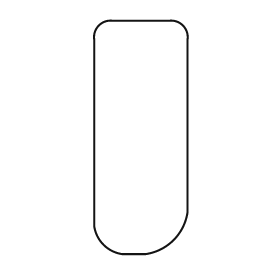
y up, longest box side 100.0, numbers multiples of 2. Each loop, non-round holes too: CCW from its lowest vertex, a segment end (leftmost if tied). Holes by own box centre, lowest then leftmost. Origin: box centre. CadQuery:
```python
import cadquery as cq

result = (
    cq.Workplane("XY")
    .moveTo(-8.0, -50.0)
    .lineTo(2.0, -50.0)
    .threePointArc((14.0, -44.0), (20.0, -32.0))
    .lineTo(20.0, 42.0)
    .threePointArc((18.0, 48.0), (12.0, 50.0))
    .lineTo(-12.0, 50.0)
    .threePointArc((-18.0, 48.0), (-20.0, 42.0))
    .lineTo(-20.0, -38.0)
    .threePointArc((-16.0, -46.0), (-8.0, -50.0))
    .close()
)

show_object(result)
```